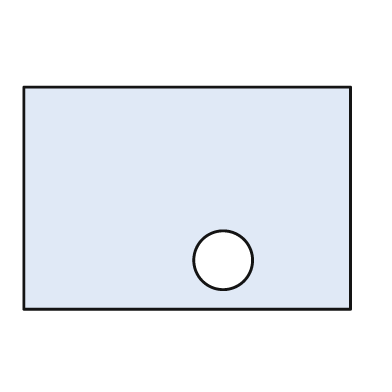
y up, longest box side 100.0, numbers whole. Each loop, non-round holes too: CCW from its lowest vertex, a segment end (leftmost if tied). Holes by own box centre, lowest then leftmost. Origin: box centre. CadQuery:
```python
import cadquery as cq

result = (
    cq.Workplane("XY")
    .moveTo(-50.0, -34.0)
    .lineTo(50.0, -34.0)
    .lineTo(50.0, 34.0)
    .lineTo(-50.0, 34.0)
    .close()
    .moveTo(11.0, -19.0)
    .circle(9.0)
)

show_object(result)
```